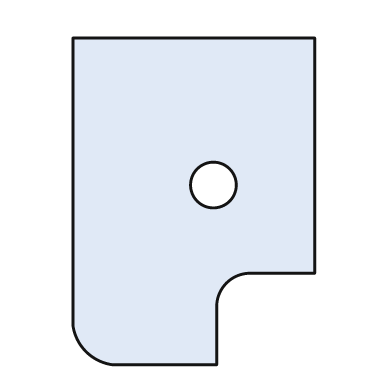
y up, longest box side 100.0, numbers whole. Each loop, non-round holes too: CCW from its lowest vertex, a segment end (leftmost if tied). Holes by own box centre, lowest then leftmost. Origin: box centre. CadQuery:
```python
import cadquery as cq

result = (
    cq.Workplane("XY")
    .moveTo(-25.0, -50.0)
    .lineTo(7.0, -50.0)
    .lineTo(7.0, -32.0)
    .threePointArc((10.0, -25.0), (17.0, -22.0))
    .lineTo(37.0, -22.0)
    .lineTo(37.0, 50.0)
    .lineTo(-37.0, 50.0)
    .lineTo(-37.0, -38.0)
    .threePointArc((-33.0, -46.0), (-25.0, -50.0))
    .close()
    .moveTo(6.0, 5.0)
    .circle(7.0)
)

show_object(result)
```